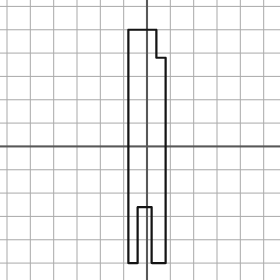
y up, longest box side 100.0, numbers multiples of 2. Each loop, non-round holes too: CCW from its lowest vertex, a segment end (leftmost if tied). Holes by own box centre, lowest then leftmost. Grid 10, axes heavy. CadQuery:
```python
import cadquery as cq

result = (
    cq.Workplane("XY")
    .moveTo(-8.0, -50.0)
    .lineTo(-4.0, -50.0)
    .lineTo(-4.0, -26.0)
    .lineTo(2.0, -26.0)
    .lineTo(2.0, -50.0)
    .lineTo(8.0, -50.0)
    .lineTo(8.0, 38.0)
    .lineTo(4.0, 38.0)
    .lineTo(4.0, 50.0)
    .lineTo(-8.0, 50.0)
    .close()
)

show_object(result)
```